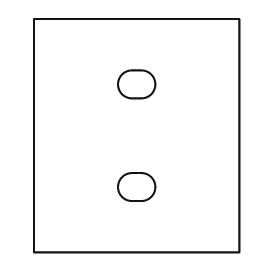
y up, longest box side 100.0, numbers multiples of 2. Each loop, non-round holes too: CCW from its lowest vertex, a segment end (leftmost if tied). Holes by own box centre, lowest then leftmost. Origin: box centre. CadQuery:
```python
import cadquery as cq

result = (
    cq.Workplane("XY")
    .moveTo(-44.0, -50.0)
    .lineTo(44.0, -50.0)
    .lineTo(44.0, 50.0)
    .lineTo(-44.0, 50.0)
    .close()
    .moveTo(-2.0, -28.0)
    .lineTo(2.0, -28.0)
    .threePointArc((8.0, -22.0), (2.0, -16.0))
    .lineTo(-2.0, -16.0)
    .threePointArc((-8.0, -22.0), (-2.0, -28.0))
    .close()
    .moveTo(-2.0, 16.0)
    .lineTo(2.0, 16.0)
    .threePointArc((8.0, 22.0), (2.0, 28.0))
    .lineTo(-2.0, 28.0)
    .threePointArc((-8.0, 22.0), (-2.0, 16.0))
    .close()
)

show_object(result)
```